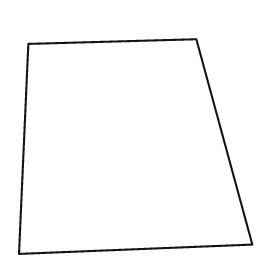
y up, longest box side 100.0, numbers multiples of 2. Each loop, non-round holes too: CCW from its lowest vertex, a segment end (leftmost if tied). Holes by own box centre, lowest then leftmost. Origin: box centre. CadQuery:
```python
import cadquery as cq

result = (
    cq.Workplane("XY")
    .moveTo(-50.0, -46.0)
    .lineTo(50.0, -42.0)
    .lineTo(26.0, 46.0)
    .lineTo(-46.0, 44.0)
    .close()
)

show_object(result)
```